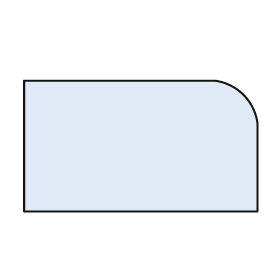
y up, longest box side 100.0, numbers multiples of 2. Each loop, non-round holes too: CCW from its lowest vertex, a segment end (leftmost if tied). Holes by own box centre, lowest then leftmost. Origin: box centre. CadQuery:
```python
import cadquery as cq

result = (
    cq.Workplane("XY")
    .moveTo(-50.0, -28.0)
    .lineTo(50.0, -28.0)
    .lineTo(50.0, 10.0)
    .threePointArc((44.0, 22.0), (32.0, 28.0))
    .lineTo(-50.0, 28.0)
    .close()
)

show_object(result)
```